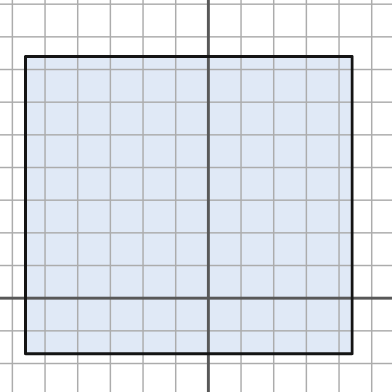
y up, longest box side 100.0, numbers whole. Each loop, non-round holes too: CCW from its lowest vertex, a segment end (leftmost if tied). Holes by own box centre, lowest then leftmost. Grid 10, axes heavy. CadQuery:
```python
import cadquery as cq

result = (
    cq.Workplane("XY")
    .moveTo(-56.0, -17.0)
    .lineTo(44.0, -17.0)
    .lineTo(44.0, 74.0)
    .lineTo(-56.0, 74.0)
    .close()
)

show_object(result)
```